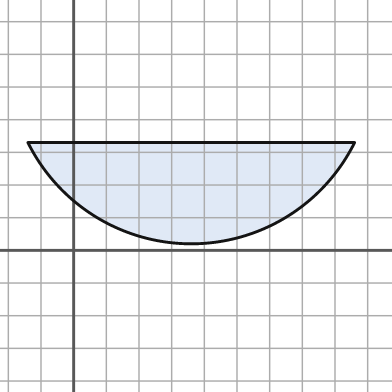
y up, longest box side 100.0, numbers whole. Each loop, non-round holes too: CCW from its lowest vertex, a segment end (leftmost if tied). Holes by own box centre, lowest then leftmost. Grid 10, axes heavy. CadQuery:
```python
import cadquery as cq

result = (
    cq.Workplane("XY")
    .moveTo(-14.0, 33.0)
    .threePointArc((36.0, 2.0), (86.0, 33.0))
    .close()
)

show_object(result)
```